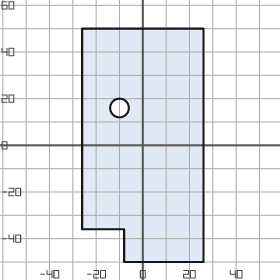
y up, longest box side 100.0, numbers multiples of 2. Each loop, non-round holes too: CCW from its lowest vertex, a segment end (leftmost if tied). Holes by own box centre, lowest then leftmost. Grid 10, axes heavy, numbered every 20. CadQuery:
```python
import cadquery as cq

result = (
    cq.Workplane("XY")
    .moveTo(-8.0, -50.0)
    .lineTo(26.0, -50.0)
    .lineTo(26.0, 50.0)
    .lineTo(-26.0, 50.0)
    .lineTo(-26.0, -36.0)
    .lineTo(-8.0, -36.0)
    .close()
    .moveTo(-10.0, 16.0)
    .circle(4.0)
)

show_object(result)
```